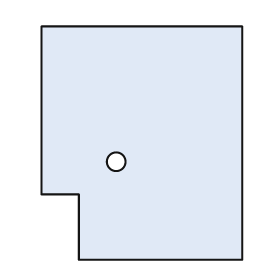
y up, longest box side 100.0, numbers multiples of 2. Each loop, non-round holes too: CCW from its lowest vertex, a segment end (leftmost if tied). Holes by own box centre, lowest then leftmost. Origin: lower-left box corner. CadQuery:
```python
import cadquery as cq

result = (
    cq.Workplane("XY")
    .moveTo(16.0, 0.0)
    .lineTo(86.0, 0.0)
    .lineTo(86.0, 100.0)
    .lineTo(0.0, 100.0)
    .lineTo(0.0, 28.0)
    .lineTo(16.0, 28.0)
    .close()
    .moveTo(32.0, 42.0)
    .circle(4.0)
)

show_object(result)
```